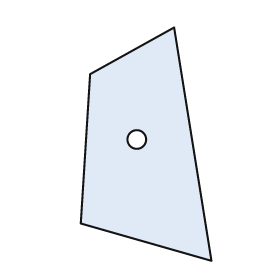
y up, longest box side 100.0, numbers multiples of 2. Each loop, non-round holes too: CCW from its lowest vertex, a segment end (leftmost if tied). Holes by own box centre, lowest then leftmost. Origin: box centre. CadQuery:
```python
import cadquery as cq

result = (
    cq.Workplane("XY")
    .moveTo(28.0, -50.0)
    .lineTo(12.0, 50.0)
    .lineTo(-24.0, 30.0)
    .lineTo(-28.0, -34.0)
    .close()
    .moveTo(-4.0, 2.0)
    .circle(4.0)
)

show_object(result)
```